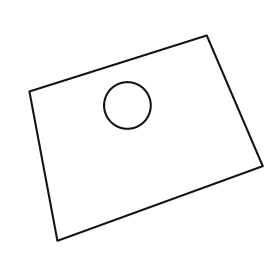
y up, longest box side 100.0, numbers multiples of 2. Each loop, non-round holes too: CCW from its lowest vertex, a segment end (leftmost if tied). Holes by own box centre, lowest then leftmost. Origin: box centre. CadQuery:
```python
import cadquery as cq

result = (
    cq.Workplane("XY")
    .moveTo(-38.0, -44.0)
    .lineTo(50.0, -12.0)
    .lineTo(26.0, 44.0)
    .lineTo(-50.0, 20.0)
    .close()
    .moveTo(-8.0, 14.0)
    .circle(10.0)
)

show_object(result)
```